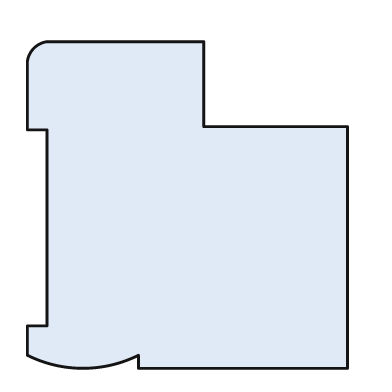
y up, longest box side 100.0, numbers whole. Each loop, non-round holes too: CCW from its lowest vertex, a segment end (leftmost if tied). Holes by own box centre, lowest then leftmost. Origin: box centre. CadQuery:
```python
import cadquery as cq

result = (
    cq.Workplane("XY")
    .moveTo(-15.0, -50.0)
    .lineTo(49.0, -50.0)
    .lineTo(49.0, 24.0)
    .lineTo(5.0, 24.0)
    .lineTo(5.0, 50.0)
    .lineTo(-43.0, 50.0)
    .threePointArc((-47.0, 48.0), (-49.0, 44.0))
    .lineTo(-49.0, 23.0)
    .lineTo(-43.0, 23.0)
    .lineTo(-43.0, -37.0)
    .lineTo(-49.0, -37.0)
    .lineTo(-49.0, -46.0)
    .threePointArc((-32.0, -50.0), (-15.0, -46.0))
    .close()
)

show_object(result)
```